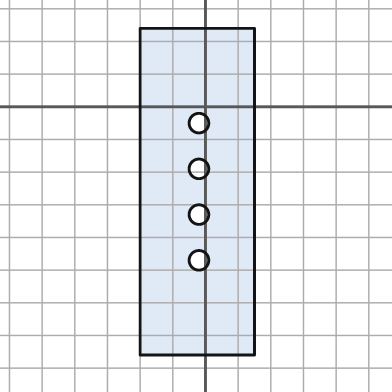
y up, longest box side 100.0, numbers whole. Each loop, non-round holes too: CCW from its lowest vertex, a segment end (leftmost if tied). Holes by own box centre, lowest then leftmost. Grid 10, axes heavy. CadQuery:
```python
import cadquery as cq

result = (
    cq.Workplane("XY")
    .moveTo(-20.0, -76.0)
    .lineTo(15.0, -76.0)
    .lineTo(15.0, 24.0)
    .lineTo(-20.0, 24.0)
    .close()
    .moveTo(-2.0, -47.0)
    .circle(3.0)
    .moveTo(-2.0, -33.0)
    .circle(3.0)
    .moveTo(-2.0, -19.0)
    .circle(3.0)
    .moveTo(-2.0, -5.0)
    .circle(3.0)
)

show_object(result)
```